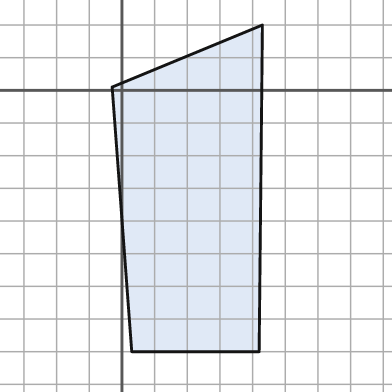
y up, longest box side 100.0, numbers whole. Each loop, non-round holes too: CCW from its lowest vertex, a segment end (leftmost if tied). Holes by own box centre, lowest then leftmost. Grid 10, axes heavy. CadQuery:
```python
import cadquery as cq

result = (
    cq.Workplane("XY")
    .moveTo(3.0, -80.0)
    .lineTo(42.0, -80.0)
    .lineTo(43.0, 20.0)
    .lineTo(-3.0, 1.0)
    .close()
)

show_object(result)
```